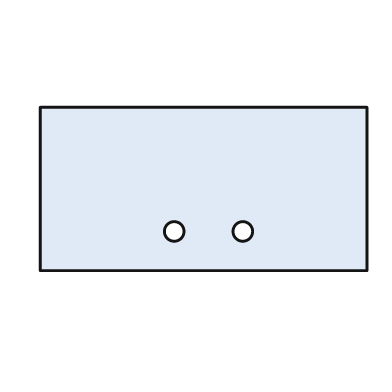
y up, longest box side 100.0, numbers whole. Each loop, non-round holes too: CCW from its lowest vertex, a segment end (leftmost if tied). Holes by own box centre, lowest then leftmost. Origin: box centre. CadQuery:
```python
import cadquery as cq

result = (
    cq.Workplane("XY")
    .moveTo(-50.0, -25.0)
    .lineTo(50.0, -25.0)
    .lineTo(50.0, 25.0)
    .lineTo(-50.0, 25.0)
    .close()
    .moveTo(-9.0, -13.0)
    .circle(3.0)
    .moveTo(12.0, -13.0)
    .circle(3.0)
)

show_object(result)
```